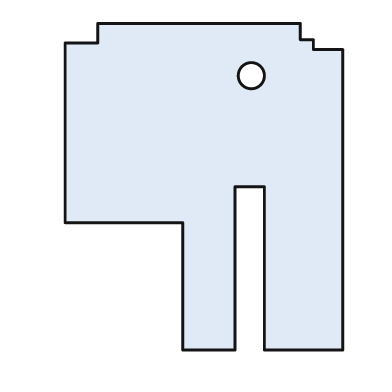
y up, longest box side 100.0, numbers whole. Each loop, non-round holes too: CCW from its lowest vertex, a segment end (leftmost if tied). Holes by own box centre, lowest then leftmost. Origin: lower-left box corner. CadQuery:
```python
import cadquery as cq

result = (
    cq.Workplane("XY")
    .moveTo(36.0, 0.0)
    .lineTo(52.0, 0.0)
    .lineTo(52.0, 50.0)
    .lineTo(61.0, 50.0)
    .lineTo(61.0, 0.0)
    .lineTo(85.0, 0.0)
    .lineTo(85.0, 92.0)
    .lineTo(76.0, 92.0)
    .lineTo(76.0, 95.0)
    .lineTo(72.0, 95.0)
    .lineTo(72.0, 100.0)
    .lineTo(10.0, 100.0)
    .lineTo(10.0, 94.0)
    .lineTo(0.0, 94.0)
    .lineTo(0.0, 39.0)
    .lineTo(36.0, 39.0)
    .close()
    .moveTo(57.0, 84.0)
    .circle(4.0)
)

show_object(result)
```